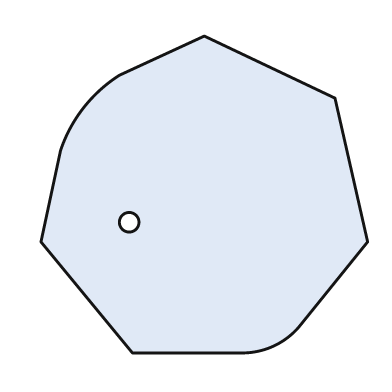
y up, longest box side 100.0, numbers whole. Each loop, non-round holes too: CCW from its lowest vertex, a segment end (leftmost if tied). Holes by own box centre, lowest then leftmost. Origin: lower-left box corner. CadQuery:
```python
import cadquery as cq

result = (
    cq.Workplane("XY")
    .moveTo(28.0, 0.0)
    .lineTo(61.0, 0.0)
    .threePointArc((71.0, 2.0), (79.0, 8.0))
    .lineTo(100.0, 34.0)
    .lineTo(90.0, 78.0)
    .lineTo(50.0, 97.0)
    .lineTo(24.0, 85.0)
    .threePointArc((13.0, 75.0), (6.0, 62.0))
    .lineTo(0.0, 34.0)
    .close()
    .moveTo(27.0, 40.0)
    .circle(3.0)
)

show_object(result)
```